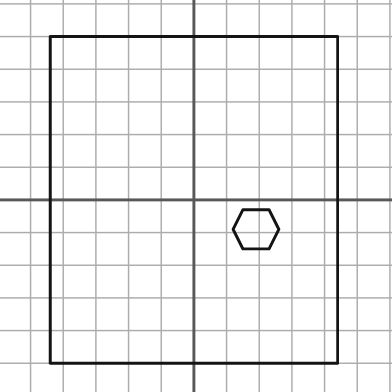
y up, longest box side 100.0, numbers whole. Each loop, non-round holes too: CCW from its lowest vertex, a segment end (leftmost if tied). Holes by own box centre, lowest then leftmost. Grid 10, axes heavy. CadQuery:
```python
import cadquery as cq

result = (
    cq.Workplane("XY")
    .moveTo(-44.0, -50.0)
    .lineTo(44.0, -50.0)
    .lineTo(44.0, 50.0)
    .lineTo(-44.0, 50.0)
    .close()
    .moveTo(15.0, -15.0)
    .lineTo(23.0, -15.0)
    .lineTo(26.0, -9.0)
    .lineTo(23.0, -3.0)
    .lineTo(15.0, -3.0)
    .lineTo(12.0, -9.0)
    .close()
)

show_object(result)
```